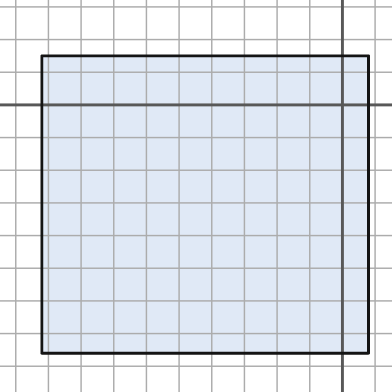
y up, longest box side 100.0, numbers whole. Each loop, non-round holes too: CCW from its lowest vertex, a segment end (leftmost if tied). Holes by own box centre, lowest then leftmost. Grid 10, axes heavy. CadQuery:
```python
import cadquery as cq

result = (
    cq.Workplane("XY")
    .moveTo(-92.0, -76.0)
    .lineTo(8.0, -76.0)
    .lineTo(8.0, 15.0)
    .lineTo(-92.0, 15.0)
    .close()
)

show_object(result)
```